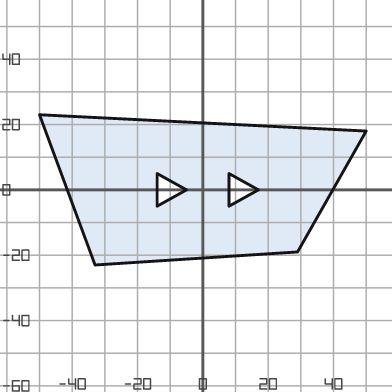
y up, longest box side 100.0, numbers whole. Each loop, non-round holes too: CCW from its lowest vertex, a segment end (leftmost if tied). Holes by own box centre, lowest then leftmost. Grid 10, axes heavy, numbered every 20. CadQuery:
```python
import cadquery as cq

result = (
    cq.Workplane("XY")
    .moveTo(-33.0, -23.0)
    .lineTo(29.0, -19.0)
    .lineTo(50.0, 18.0)
    .lineTo(-50.0, 23.0)
    .close()
    .moveTo(-14.0, -5.0)
    .lineTo(-5.0, 0.0)
    .lineTo(-14.0, 5.0)
    .close()
    .moveTo(8.0, -5.0)
    .lineTo(17.0, 0.0)
    .lineTo(8.0, 5.0)
    .close()
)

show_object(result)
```